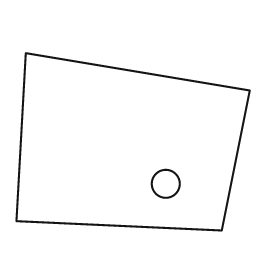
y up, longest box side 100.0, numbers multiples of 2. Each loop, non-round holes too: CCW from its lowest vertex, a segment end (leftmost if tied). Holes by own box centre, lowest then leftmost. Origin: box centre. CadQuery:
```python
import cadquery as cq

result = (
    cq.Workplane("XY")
    .moveTo(38.0, -38.0)
    .lineTo(50.0, 22.0)
    .lineTo(-46.0, 38.0)
    .lineTo(-50.0, -34.0)
    .close()
    .moveTo(14.0, -18.0)
    .circle(6.0)
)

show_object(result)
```